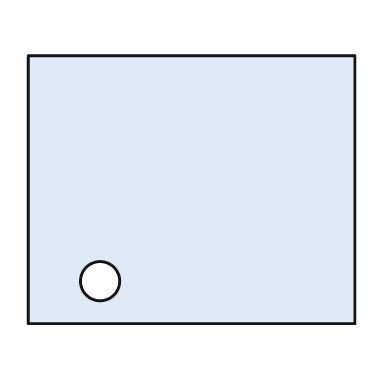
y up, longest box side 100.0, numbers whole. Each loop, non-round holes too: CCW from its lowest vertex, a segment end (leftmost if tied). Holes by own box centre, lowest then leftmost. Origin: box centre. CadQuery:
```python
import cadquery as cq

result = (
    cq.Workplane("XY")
    .moveTo(-50.0, -41.0)
    .lineTo(50.0, -41.0)
    .lineTo(50.0, 41.0)
    .lineTo(-50.0, 41.0)
    .close()
    .moveTo(-28.0, -28.0)
    .circle(6.0)
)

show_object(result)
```